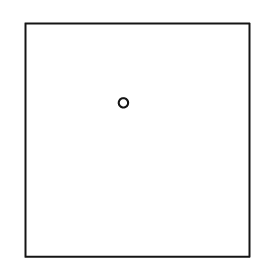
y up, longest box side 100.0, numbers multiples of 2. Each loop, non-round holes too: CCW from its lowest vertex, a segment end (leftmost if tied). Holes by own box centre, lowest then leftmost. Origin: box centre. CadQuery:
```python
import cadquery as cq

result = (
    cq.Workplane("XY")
    .moveTo(-48.0, -50.0)
    .lineTo(48.0, -50.0)
    .lineTo(48.0, 50.0)
    .lineTo(-48.0, 50.0)
    .close()
    .moveTo(-6.0, 16.0)
    .circle(2.0)
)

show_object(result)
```